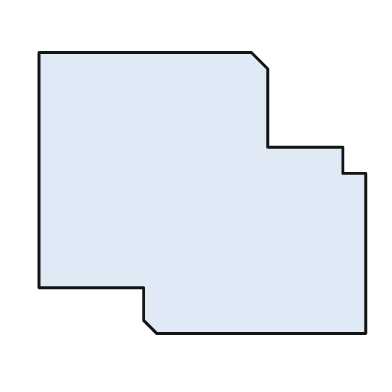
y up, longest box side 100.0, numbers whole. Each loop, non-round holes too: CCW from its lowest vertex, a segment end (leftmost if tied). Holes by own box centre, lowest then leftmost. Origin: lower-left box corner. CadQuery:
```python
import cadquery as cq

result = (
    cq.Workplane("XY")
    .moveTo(36.0, 0.0)
    .lineTo(100.0, 0.0)
    .lineTo(100.0, 49.0)
    .lineTo(93.0, 49.0)
    .lineTo(93.0, 57.0)
    .lineTo(70.0, 57.0)
    .lineTo(70.0, 81.0)
    .lineTo(65.0, 86.0)
    .lineTo(0.0, 86.0)
    .lineTo(0.0, 14.0)
    .lineTo(32.0, 14.0)
    .lineTo(32.0, 4.0)
    .close()
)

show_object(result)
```